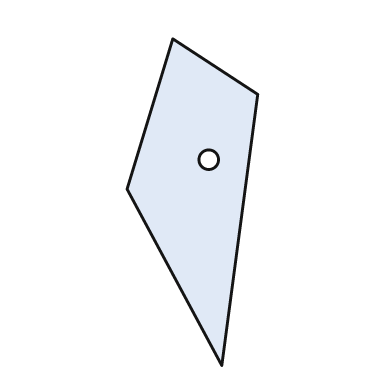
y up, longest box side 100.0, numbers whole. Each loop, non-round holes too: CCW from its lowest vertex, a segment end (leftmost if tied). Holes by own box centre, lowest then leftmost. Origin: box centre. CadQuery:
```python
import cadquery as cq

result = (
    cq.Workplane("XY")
    .moveTo(9.0, -50.0)
    .lineTo(20.0, 33.0)
    .lineTo(-6.0, 50.0)
    .lineTo(-20.0, 4.0)
    .close()
    .moveTo(5.0, 13.0)
    .circle(3.0)
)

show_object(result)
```